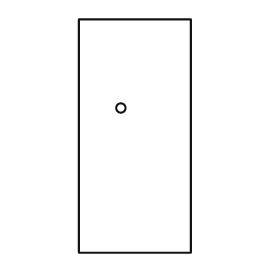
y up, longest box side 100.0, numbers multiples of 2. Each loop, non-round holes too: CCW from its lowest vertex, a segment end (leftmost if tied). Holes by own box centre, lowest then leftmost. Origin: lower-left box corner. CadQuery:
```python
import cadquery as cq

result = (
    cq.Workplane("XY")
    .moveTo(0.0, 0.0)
    .lineTo(48.0, 0.0)
    .lineTo(48.0, 100.0)
    .lineTo(0.0, 100.0)
    .close()
    .moveTo(18.0, 62.0)
    .circle(2.0)
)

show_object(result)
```